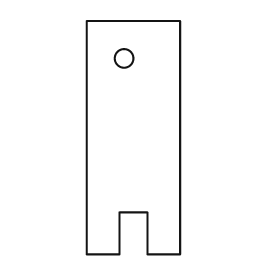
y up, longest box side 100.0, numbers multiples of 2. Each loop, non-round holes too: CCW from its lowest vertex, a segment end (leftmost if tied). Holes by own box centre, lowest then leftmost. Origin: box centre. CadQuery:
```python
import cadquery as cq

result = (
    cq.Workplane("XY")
    .moveTo(-20.0, -50.0)
    .lineTo(-6.0, -50.0)
    .lineTo(-6.0, -32.0)
    .lineTo(6.0, -32.0)
    .lineTo(6.0, -50.0)
    .lineTo(20.0, -50.0)
    .lineTo(20.0, 50.0)
    .lineTo(-20.0, 50.0)
    .close()
    .moveTo(-4.0, 34.0)
    .circle(4.0)
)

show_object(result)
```